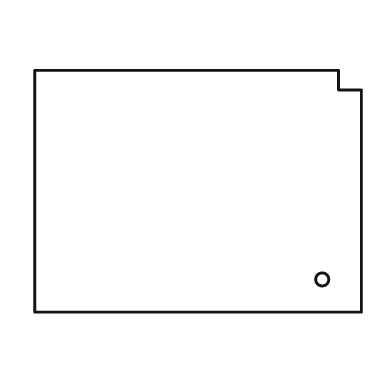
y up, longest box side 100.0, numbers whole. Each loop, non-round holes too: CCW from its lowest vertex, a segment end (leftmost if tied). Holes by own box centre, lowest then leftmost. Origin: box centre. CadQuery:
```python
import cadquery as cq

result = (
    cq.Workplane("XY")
    .moveTo(-50.0, -37.0)
    .lineTo(50.0, -37.0)
    .lineTo(50.0, 31.0)
    .lineTo(43.0, 31.0)
    .lineTo(43.0, 37.0)
    .lineTo(-50.0, 37.0)
    .close()
    .moveTo(38.0, -27.0)
    .circle(2.0)
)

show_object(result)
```